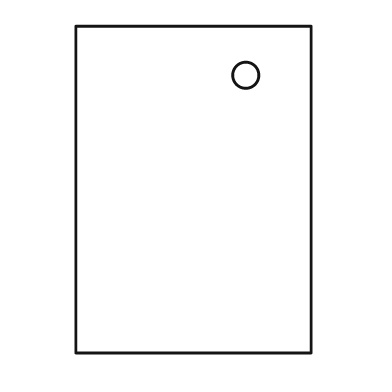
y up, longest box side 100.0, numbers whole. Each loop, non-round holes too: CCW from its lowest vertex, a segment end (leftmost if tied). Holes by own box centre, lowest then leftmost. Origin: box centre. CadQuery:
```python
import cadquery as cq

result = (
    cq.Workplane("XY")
    .moveTo(-36.0, -50.0)
    .lineTo(36.0, -50.0)
    .lineTo(36.0, 50.0)
    .lineTo(-36.0, 50.0)
    .close()
    .moveTo(16.0, 35.0)
    .circle(4.0)
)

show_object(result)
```